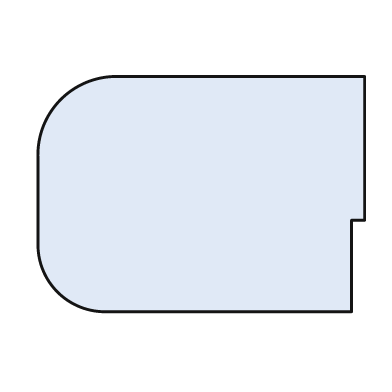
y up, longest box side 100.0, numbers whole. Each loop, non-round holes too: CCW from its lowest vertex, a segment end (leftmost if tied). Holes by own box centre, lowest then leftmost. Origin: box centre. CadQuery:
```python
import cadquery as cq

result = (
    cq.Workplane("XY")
    .moveTo(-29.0, -36.0)
    .lineTo(46.0, -36.0)
    .lineTo(46.0, -8.0)
    .lineTo(50.0, -8.0)
    .lineTo(50.0, 36.0)
    .lineTo(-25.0, 36.0)
    .threePointArc((-43.0, 29.0), (-50.0, 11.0))
    .lineTo(-50.0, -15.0)
    .threePointArc((-44.0, -30.0), (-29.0, -36.0))
    .close()
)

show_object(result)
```